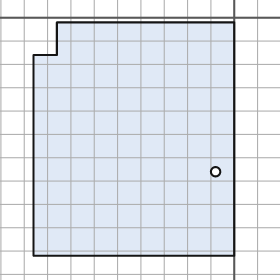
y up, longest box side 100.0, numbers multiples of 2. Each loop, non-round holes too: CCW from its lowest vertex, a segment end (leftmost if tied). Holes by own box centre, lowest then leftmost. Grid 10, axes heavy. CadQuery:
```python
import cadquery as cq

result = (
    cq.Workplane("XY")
    .moveTo(-86.0, -102.0)
    .lineTo(0.0, -102.0)
    .lineTo(0.0, -2.0)
    .lineTo(-76.0, -2.0)
    .lineTo(-76.0, -16.0)
    .lineTo(-86.0, -16.0)
    .close()
    .moveTo(-8.0, -66.0)
    .circle(2.0)
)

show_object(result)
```